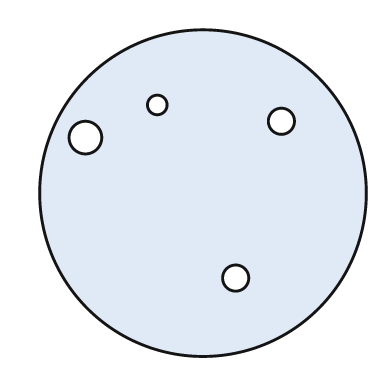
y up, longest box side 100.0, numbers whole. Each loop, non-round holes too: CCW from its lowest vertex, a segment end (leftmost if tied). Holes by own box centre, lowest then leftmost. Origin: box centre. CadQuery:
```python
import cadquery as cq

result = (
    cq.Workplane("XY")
    .moveTo(0.0, 0.0)
    .circle(50.0)
    .moveTo(10.0, -26.0)
    .circle(4.0)
    .moveTo(-36.0, 17.0)
    .circle(5.0)
    .moveTo(24.0, 22.0)
    .circle(4.0)
    .moveTo(-14.0, 27.0)
    .circle(3.0)
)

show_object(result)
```